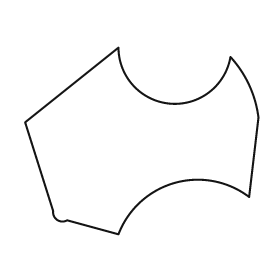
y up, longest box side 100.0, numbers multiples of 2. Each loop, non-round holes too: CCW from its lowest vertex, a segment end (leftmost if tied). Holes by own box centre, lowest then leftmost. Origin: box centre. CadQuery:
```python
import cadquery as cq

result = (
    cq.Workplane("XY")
    .moveTo(-10.0, -40.0)
    .threePointArc((14.0, -18.0), (46.0, -24.0))
    .lineTo(50.0, 10.0)
    .threePointArc((46.0, 24.0), (38.0, 36.0))
    .threePointArc((12.0, 16.0), (-10.0, 40.0))
    .lineTo(-50.0, 8.0)
    .lineTo(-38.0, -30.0)
    .threePointArc((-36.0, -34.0), (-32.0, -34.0))
    .close()
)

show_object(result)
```